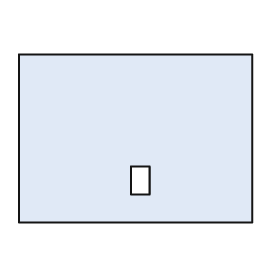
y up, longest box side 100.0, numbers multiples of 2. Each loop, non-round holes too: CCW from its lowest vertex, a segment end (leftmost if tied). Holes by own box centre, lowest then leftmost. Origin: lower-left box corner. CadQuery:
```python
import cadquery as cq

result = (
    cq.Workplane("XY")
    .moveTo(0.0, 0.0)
    .lineTo(100.0, 0.0)
    .lineTo(100.0, 72.0)
    .lineTo(0.0, 72.0)
    .close()
    .moveTo(48.0, 12.0)
    .lineTo(56.0, 12.0)
    .lineTo(56.0, 24.0)
    .lineTo(48.0, 24.0)
    .close()
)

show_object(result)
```